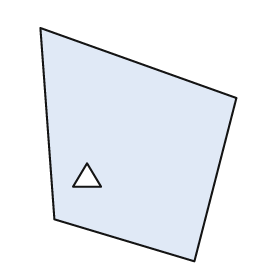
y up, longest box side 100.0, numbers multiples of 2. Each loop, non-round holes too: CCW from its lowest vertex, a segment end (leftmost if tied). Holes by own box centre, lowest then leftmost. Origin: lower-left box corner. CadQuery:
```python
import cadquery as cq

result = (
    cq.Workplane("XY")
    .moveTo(66.0, 0.0)
    .lineTo(84.0, 70.0)
    .lineTo(0.0, 100.0)
    .lineTo(6.0, 18.0)
    .close()
    .moveTo(14.0, 32.0)
    .lineTo(26.0, 32.0)
    .lineTo(20.0, 42.0)
    .close()
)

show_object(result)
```